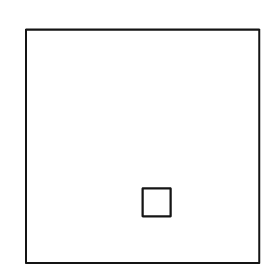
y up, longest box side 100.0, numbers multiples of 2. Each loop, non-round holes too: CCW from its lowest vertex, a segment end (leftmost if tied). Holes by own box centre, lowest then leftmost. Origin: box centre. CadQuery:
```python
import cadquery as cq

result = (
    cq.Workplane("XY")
    .moveTo(-50.0, -50.0)
    .lineTo(50.0, -50.0)
    .lineTo(50.0, 50.0)
    .lineTo(-50.0, 50.0)
    .close()
    .moveTo(0.0, -30.0)
    .lineTo(12.0, -30.0)
    .lineTo(12.0, -18.0)
    .lineTo(0.0, -18.0)
    .close()
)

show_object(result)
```